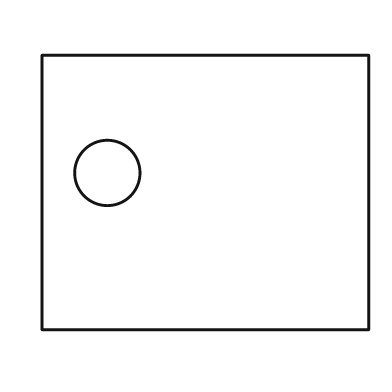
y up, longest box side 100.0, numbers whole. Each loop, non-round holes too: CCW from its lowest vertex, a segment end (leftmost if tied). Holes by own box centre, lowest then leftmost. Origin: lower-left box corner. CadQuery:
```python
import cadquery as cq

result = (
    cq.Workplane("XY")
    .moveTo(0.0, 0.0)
    .lineTo(100.0, 0.0)
    .lineTo(100.0, 84.0)
    .lineTo(0.0, 84.0)
    .close()
    .moveTo(20.0, 48.0)
    .circle(10.0)
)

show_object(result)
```